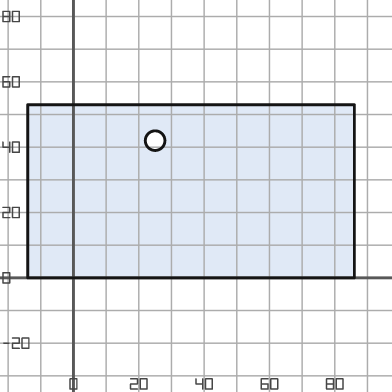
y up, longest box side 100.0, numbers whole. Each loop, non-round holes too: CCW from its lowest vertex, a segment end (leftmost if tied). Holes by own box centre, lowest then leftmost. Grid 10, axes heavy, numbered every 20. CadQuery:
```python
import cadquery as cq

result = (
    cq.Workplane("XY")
    .moveTo(-14.0, 0.0)
    .lineTo(86.0, 0.0)
    .lineTo(86.0, 53.0)
    .lineTo(-14.0, 53.0)
    .close()
    .moveTo(25.0, 42.0)
    .circle(3.0)
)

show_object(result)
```